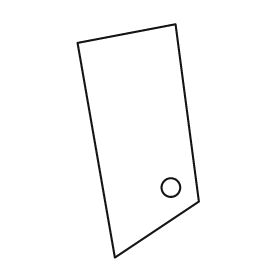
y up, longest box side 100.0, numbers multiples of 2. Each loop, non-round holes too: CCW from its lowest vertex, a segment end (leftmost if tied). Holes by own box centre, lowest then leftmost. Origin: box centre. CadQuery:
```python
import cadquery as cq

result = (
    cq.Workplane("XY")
    .moveTo(-10.0, -50.0)
    .lineTo(26.0, -26.0)
    .lineTo(16.0, 50.0)
    .lineTo(-26.0, 42.0)
    .close()
    .moveTo(14.0, -20.0)
    .circle(4.0)
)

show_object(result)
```